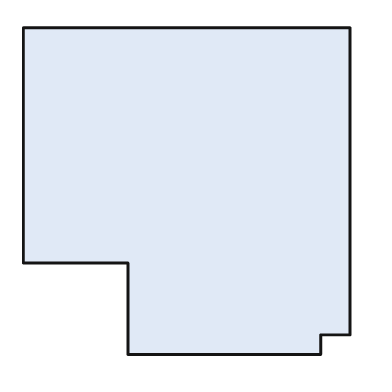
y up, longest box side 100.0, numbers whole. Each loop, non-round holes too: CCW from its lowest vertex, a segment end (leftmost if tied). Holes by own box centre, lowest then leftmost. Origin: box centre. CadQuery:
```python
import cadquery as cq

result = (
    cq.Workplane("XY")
    .moveTo(-18.0, -50.0)
    .lineTo(41.0, -50.0)
    .lineTo(41.0, -44.0)
    .lineTo(50.0, -44.0)
    .lineTo(50.0, 50.0)
    .lineTo(-50.0, 50.0)
    .lineTo(-50.0, -22.0)
    .lineTo(-18.0, -22.0)
    .close()
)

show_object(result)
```